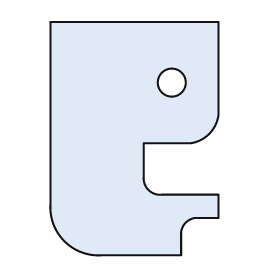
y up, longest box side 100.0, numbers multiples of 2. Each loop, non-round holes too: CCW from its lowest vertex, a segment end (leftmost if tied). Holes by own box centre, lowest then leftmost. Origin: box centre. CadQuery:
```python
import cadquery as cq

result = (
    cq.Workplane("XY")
    .moveTo(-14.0, -50.0)
    .lineTo(20.0, -50.0)
    .lineTo(20.0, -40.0)
    .threePointArc((22.0, -36.0), (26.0, -34.0))
    .lineTo(36.0, -34.0)
    .lineTo(36.0, -24.0)
    .lineTo(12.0, -24.0)
    .threePointArc((6.0, -22.0), (4.0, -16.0))
    .lineTo(4.0, -2.0)
    .lineTo(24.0, -2.0)
    .threePointArc((32.0, 2.0), (36.0, 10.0))
    .lineTo(36.0, 50.0)
    .lineTo(-36.0, 50.0)
    .lineTo(-36.0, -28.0)
    .threePointArc((-30.0, -44.0), (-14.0, -50.0))
    .close()
    .moveTo(16.0, 24.0)
    .circle(6.0)
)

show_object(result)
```